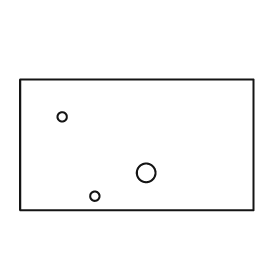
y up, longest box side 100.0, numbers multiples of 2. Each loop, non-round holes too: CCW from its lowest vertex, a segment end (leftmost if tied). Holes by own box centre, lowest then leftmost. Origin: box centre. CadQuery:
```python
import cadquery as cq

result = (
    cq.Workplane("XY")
    .moveTo(-50.0, -28.0)
    .lineTo(50.0, -28.0)
    .lineTo(50.0, 28.0)
    .lineTo(-50.0, 28.0)
    .close()
    .moveTo(-18.0, -22.0)
    .circle(2.0)
    .moveTo(4.0, -12.0)
    .circle(4.0)
    .moveTo(-32.0, 12.0)
    .circle(2.0)
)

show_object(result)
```